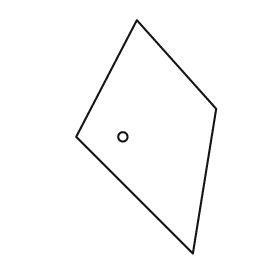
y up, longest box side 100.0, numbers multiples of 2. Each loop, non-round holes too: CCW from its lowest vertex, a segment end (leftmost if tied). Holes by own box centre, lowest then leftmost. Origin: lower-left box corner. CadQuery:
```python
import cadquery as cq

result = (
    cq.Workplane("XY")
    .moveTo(50.0, 0.0)
    .lineTo(60.0, 62.0)
    .lineTo(26.0, 100.0)
    .lineTo(0.0, 50.0)
    .close()
    .moveTo(20.0, 50.0)
    .circle(2.0)
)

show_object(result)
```